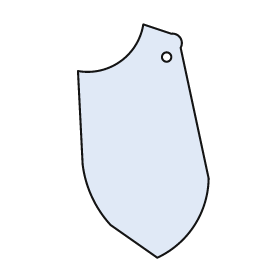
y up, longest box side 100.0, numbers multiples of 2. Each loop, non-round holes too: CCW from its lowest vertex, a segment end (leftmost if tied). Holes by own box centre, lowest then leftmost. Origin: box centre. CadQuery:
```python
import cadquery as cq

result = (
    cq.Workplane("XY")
    .moveTo(6.0, -50.0)
    .threePointArc((22.0, -36.0), (28.0, -16.0))
    .lineTo(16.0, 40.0)
    .threePointArc((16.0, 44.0), (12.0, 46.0))
    .lineTo(0.0, 50.0)
    .threePointArc((-10.0, 34.0), (-28.0, 30.0))
    .lineTo(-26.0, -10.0)
    .threePointArc((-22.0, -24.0), (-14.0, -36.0))
    .close()
    .moveTo(10.0, 36.0)
    .circle(2.0)
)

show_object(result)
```